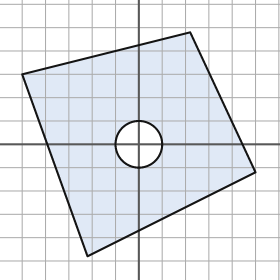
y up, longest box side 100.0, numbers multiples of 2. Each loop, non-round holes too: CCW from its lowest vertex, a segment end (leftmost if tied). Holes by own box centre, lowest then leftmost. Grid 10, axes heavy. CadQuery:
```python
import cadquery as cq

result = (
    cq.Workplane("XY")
    .moveTo(-22.0, -48.0)
    .lineTo(50.0, -12.0)
    .lineTo(22.0, 48.0)
    .lineTo(-50.0, 30.0)
    .close()
    .moveTo(0.0, 0.0)
    .circle(10.0)
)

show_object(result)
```